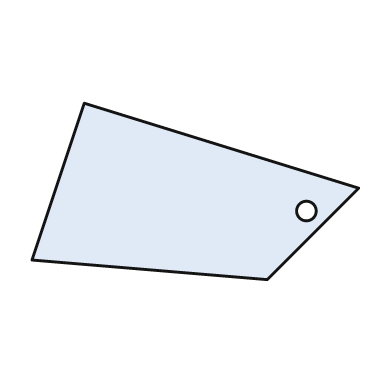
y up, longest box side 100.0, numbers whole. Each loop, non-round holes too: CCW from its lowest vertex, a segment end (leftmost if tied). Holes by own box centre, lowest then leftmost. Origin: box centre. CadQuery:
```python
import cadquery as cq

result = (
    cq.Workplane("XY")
    .moveTo(22.0, -27.0)
    .lineTo(50.0, 1.0)
    .lineTo(-34.0, 27.0)
    .lineTo(-50.0, -21.0)
    .close()
    .moveTo(34.0, -6.0)
    .circle(3.0)
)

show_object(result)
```